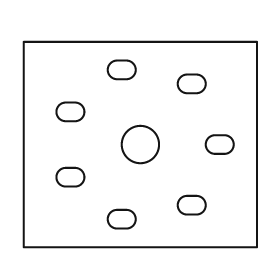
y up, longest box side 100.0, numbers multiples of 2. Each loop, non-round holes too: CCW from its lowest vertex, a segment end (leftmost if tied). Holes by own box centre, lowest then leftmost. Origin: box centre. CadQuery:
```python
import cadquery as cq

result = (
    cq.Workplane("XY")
    .moveTo(-50.0, -44.0)
    .lineTo(50.0, -44.0)
    .lineTo(50.0, 44.0)
    .lineTo(-50.0, 44.0)
    .close()
    .moveTo(-10.0, -36.0)
    .lineTo(-6.0, -36.0)
    .threePointArc((-2.0, -32.0), (-6.0, -28.0))
    .lineTo(-10.0, -28.0)
    .threePointArc((-14.0, -32.0), (-10.0, -36.0))
    .close()
    .moveTo(20.0, -30.0)
    .lineTo(24.0, -30.0)
    .threePointArc((28.0, -26.0), (24.0, -22.0))
    .lineTo(20.0, -22.0)
    .threePointArc((16.0, -26.0), (20.0, -30.0))
    .close()
    .moveTo(-32.0, -18.0)
    .lineTo(-28.0, -18.0)
    .threePointArc((-24.0, -14.0), (-28.0, -10.0))
    .lineTo(-32.0, -10.0)
    .threePointArc((-36.0, -14.0), (-32.0, -18.0))
    .close()
    .moveTo(0.0, 0.0)
    .circle(8.0)
    .moveTo(32.0, -4.0)
    .lineTo(36.0, -4.0)
    .threePointArc((40.0, 0.0), (36.0, 4.0))
    .lineTo(32.0, 4.0)
    .threePointArc((28.0, 0.0), (32.0, -4.0))
    .close()
    .moveTo(-32.0, 10.0)
    .lineTo(-28.0, 10.0)
    .threePointArc((-24.0, 14.0), (-28.0, 18.0))
    .lineTo(-32.0, 18.0)
    .threePointArc((-36.0, 14.0), (-32.0, 10.0))
    .close()
    .moveTo(20.0, 22.0)
    .lineTo(24.0, 22.0)
    .threePointArc((28.0, 26.0), (24.0, 30.0))
    .lineTo(20.0, 30.0)
    .threePointArc((16.0, 26.0), (20.0, 22.0))
    .close()
    .moveTo(-10.0, 28.0)
    .lineTo(-6.0, 28.0)
    .threePointArc((-2.0, 32.0), (-6.0, 36.0))
    .lineTo(-10.0, 36.0)
    .threePointArc((-14.0, 32.0), (-10.0, 28.0))
    .close()
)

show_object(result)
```